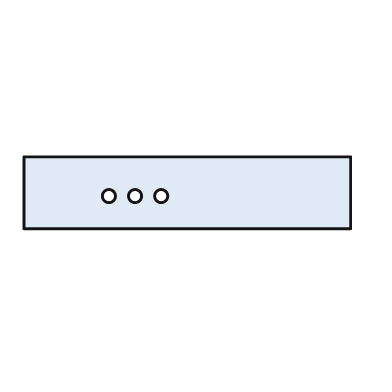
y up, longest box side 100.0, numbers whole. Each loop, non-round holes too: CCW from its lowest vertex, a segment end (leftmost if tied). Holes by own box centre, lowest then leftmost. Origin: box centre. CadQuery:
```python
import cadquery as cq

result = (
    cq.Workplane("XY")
    .moveTo(-50.0, -11.0)
    .lineTo(50.0, -11.0)
    .lineTo(50.0, 11.0)
    .lineTo(-50.0, 11.0)
    .close()
    .moveTo(-24.0, -1.0)
    .circle(2.0)
    .moveTo(-16.0, -1.0)
    .circle(2.0)
    .moveTo(-8.0, -1.0)
    .circle(2.0)
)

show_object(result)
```